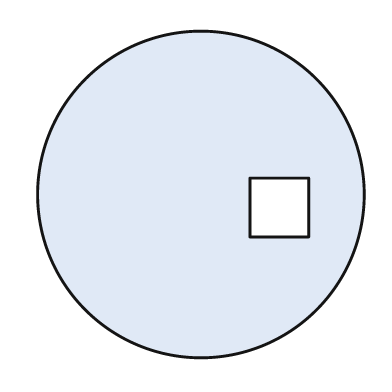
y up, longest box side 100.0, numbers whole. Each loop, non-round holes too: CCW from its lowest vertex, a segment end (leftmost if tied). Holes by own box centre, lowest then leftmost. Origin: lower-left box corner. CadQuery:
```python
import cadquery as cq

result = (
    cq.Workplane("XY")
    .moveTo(50.0, 50.0)
    .circle(50.0)
    .moveTo(65.0, 37.0)
    .lineTo(83.0, 37.0)
    .lineTo(83.0, 55.0)
    .lineTo(65.0, 55.0)
    .close()
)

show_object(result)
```